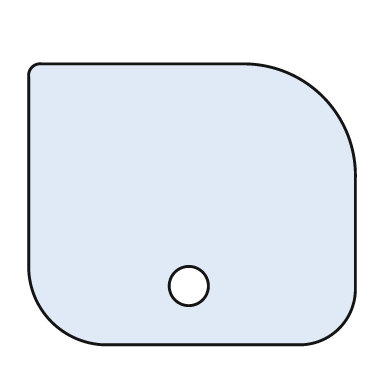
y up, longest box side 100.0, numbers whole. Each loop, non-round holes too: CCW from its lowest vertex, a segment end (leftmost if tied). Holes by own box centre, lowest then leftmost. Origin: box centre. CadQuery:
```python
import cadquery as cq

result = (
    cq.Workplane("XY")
    .moveTo(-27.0, -43.0)
    .lineTo(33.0, -43.0)
    .threePointArc((45.0, -38.0), (50.0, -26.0))
    .lineTo(50.0, 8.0)
    .threePointArc((40.0, 33.0), (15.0, 43.0))
    .lineTo(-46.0, 43.0)
    .threePointArc((-49.0, 42.0), (-50.0, 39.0))
    .lineTo(-50.0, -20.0)
    .threePointArc((-43.0, -36.0), (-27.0, -43.0))
    .close()
    .moveTo(-1.0, -25.0)
    .circle(6.0)
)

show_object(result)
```